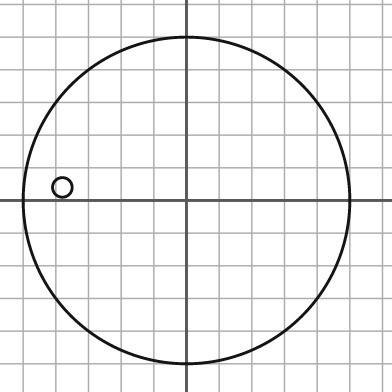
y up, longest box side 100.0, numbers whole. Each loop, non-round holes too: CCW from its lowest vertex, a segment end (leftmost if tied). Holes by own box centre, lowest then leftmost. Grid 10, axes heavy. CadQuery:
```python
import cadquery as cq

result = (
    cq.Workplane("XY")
    .moveTo(0.0, 0.0)
    .circle(50.0)
    .moveTo(-38.0, 4.0)
    .circle(3.0)
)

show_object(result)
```